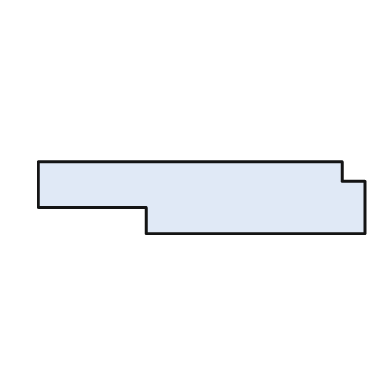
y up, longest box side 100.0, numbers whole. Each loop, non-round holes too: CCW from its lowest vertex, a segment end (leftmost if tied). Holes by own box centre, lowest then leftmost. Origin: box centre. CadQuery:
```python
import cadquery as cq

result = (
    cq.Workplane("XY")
    .moveTo(-17.0, -11.0)
    .lineTo(50.0, -11.0)
    .lineTo(50.0, 5.0)
    .lineTo(43.0, 5.0)
    .lineTo(43.0, 11.0)
    .lineTo(-50.0, 11.0)
    .lineTo(-50.0, -3.0)
    .lineTo(-17.0, -3.0)
    .close()
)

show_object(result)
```